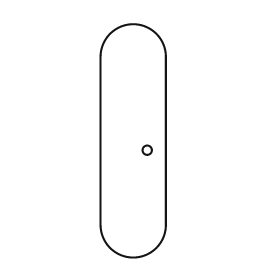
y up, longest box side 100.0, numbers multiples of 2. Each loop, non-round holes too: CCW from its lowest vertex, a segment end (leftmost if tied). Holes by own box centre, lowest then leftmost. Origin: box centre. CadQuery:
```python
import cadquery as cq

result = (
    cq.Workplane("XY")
    .moveTo(-14.0, -36.0)
    .threePointArc((0.0, -50.0), (14.0, -36.0))
    .lineTo(14.0, 36.0)
    .threePointArc((0.0, 50.0), (-14.0, 36.0))
    .close()
    .moveTo(6.0, -4.0)
    .circle(2.0)
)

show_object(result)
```